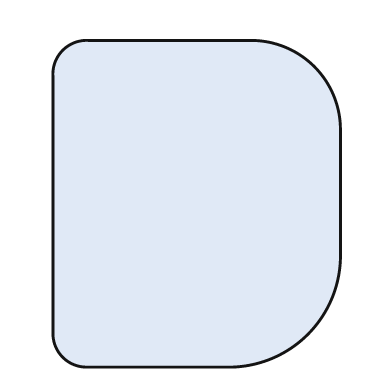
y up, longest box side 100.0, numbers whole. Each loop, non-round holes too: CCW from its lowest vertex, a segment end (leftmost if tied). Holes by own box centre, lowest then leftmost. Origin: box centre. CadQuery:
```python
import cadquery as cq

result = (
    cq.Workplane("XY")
    .moveTo(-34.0, -50.0)
    .lineTo(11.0, -50.0)
    .threePointArc((34.0, -40.0), (44.0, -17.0))
    .lineTo(44.0, 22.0)
    .threePointArc((36.0, 42.0), (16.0, 50.0))
    .lineTo(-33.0, 50.0)
    .threePointArc((-41.0, 47.0), (-44.0, 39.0))
    .lineTo(-44.0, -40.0)
    .threePointArc((-41.0, -47.0), (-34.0, -50.0))
    .close()
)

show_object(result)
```